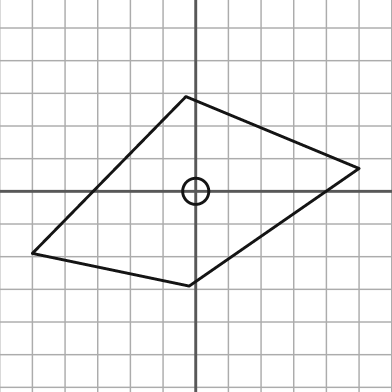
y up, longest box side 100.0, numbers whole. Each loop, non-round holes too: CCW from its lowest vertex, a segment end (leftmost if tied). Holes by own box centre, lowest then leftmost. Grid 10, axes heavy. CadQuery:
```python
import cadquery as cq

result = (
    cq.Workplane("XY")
    .moveTo(-2.0, -29.0)
    .lineTo(50.0, 7.0)
    .lineTo(-3.0, 29.0)
    .lineTo(-50.0, -19.0)
    .close()
    .moveTo(0.0, 0.0)
    .circle(4.0)
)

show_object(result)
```